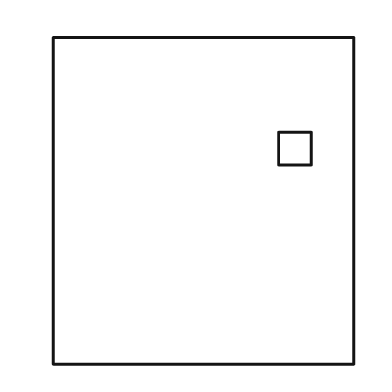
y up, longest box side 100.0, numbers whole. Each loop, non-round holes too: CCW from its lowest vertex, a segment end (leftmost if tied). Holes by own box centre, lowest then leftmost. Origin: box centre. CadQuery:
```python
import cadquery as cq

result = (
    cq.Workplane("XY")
    .moveTo(-46.0, -50.0)
    .lineTo(46.0, -50.0)
    .lineTo(46.0, 50.0)
    .lineTo(-46.0, 50.0)
    .close()
    .moveTo(23.0, 11.0)
    .lineTo(33.0, 11.0)
    .lineTo(33.0, 21.0)
    .lineTo(23.0, 21.0)
    .close()
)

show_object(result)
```